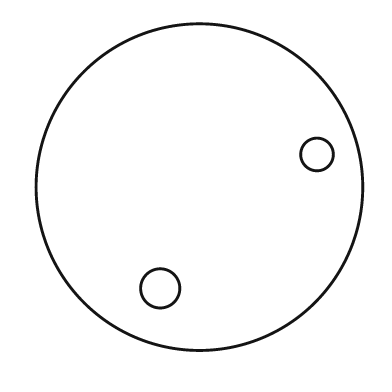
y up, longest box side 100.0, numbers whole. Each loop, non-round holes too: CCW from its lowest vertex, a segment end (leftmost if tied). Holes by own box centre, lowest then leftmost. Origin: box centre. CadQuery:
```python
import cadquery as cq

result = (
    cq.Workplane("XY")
    .moveTo(0.0, 0.0)
    .circle(50.0)
    .moveTo(-12.0, -31.0)
    .circle(6.0)
    .moveTo(36.0, 10.0)
    .circle(5.0)
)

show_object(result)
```